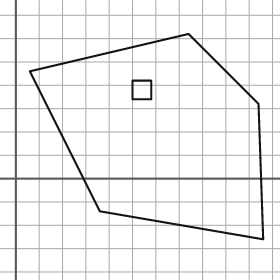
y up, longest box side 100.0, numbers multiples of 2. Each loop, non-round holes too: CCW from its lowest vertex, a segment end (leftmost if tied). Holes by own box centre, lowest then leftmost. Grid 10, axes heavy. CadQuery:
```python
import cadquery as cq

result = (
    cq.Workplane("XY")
    .moveTo(106.0, -26.0)
    .lineTo(104.0, 32.0)
    .lineTo(74.0, 62.0)
    .lineTo(6.0, 46.0)
    .lineTo(36.0, -14.0)
    .close()
    .moveTo(50.0, 34.0)
    .lineTo(58.0, 34.0)
    .lineTo(58.0, 42.0)
    .lineTo(50.0, 42.0)
    .close()
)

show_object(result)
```